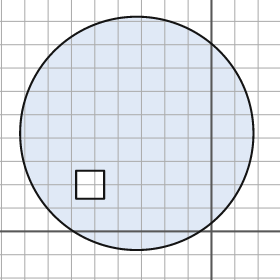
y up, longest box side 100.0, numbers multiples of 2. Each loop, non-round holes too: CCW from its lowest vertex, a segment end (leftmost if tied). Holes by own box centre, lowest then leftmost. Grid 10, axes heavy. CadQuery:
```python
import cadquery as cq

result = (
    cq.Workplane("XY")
    .moveTo(-32.0, 42.0)
    .circle(50.0)
    .moveTo(-58.0, 14.0)
    .lineTo(-46.0, 14.0)
    .lineTo(-46.0, 26.0)
    .lineTo(-58.0, 26.0)
    .close()
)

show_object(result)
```